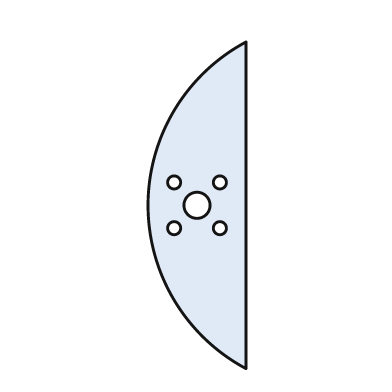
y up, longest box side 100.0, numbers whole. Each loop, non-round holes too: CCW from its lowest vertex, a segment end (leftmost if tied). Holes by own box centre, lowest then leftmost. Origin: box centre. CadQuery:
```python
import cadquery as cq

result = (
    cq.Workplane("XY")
    .moveTo(15.0, -50.0)
    .lineTo(15.0, 50.0)
    .threePointArc((-15.0, 0.0), (15.0, -50.0))
    .close()
    .moveTo(-7.0, -7.0)
    .circle(2.0)
    .moveTo(7.0, -7.0)
    .circle(2.0)
    .moveTo(0.0, 0.0)
    .circle(4.0)
    .moveTo(-7.0, 7.0)
    .circle(2.0)
    .moveTo(7.0, 7.0)
    .circle(2.0)
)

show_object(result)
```